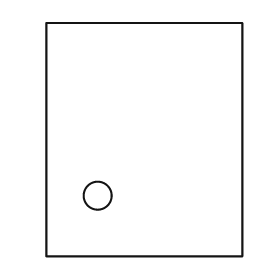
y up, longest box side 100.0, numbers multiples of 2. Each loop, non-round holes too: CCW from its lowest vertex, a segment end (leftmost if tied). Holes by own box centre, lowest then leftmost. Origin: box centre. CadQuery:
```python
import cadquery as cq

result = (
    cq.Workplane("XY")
    .moveTo(-42.0, -50.0)
    .lineTo(42.0, -50.0)
    .lineTo(42.0, 50.0)
    .lineTo(-42.0, 50.0)
    .close()
    .moveTo(-20.0, -24.0)
    .circle(6.0)
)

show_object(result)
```